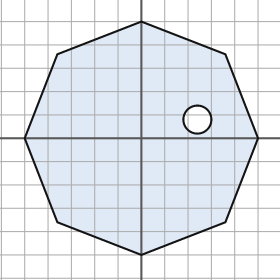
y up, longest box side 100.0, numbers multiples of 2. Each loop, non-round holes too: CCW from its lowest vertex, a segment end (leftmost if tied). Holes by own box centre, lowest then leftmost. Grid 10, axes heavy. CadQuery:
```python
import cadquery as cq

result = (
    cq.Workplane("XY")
    .moveTo(0.0, -50.0)
    .lineTo(36.0, -36.0)
    .lineTo(50.0, 0.0)
    .lineTo(36.0, 36.0)
    .lineTo(0.0, 50.0)
    .lineTo(-36.0, 36.0)
    .lineTo(-50.0, 0.0)
    .lineTo(-36.0, -36.0)
    .close()
    .moveTo(24.0, 8.0)
    .circle(6.0)
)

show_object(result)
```